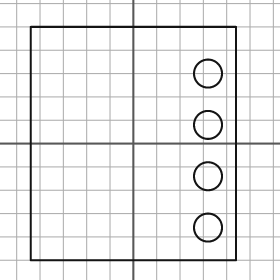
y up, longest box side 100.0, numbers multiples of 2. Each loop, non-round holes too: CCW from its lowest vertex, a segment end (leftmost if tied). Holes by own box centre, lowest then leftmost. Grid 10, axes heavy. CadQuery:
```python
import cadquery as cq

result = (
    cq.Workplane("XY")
    .moveTo(-44.0, -50.0)
    .lineTo(44.0, -50.0)
    .lineTo(44.0, 50.0)
    .lineTo(-44.0, 50.0)
    .close()
    .moveTo(32.0, -36.0)
    .circle(6.0)
    .moveTo(32.0, -14.0)
    .circle(6.0)
    .moveTo(32.0, 8.0)
    .circle(6.0)
    .moveTo(32.0, 30.0)
    .circle(6.0)
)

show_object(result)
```